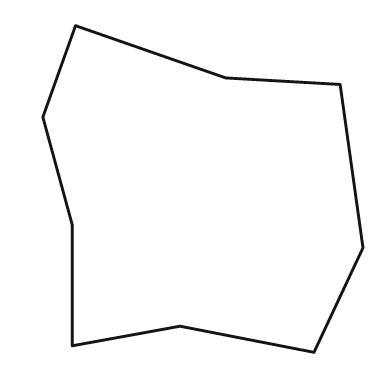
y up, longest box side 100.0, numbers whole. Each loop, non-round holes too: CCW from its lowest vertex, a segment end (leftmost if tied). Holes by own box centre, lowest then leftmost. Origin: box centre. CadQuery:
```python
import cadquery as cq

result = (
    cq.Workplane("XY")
    .moveTo(34.0, -50.0)
    .lineTo(49.0, -18.0)
    .lineTo(42.0, 32.0)
    .lineTo(7.0, 34.0)
    .lineTo(-39.0, 50.0)
    .lineTo(-49.0, 22.0)
    .lineTo(-40.0, -11.0)
    .lineTo(-40.0, -48.0)
    .lineTo(-7.0, -42.0)
    .close()
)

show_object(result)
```